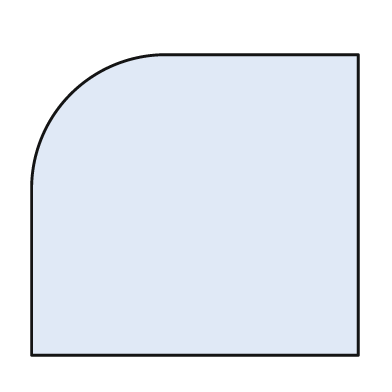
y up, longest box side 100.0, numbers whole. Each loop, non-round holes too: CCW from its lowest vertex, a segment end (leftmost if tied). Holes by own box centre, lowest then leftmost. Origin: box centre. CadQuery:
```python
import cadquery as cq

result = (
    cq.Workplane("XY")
    .moveTo(-50.0, -46.0)
    .lineTo(50.0, -46.0)
    .lineTo(50.0, 46.0)
    .lineTo(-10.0, 46.0)
    .threePointArc((-38.0, 34.0), (-50.0, 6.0))
    .close()
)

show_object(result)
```